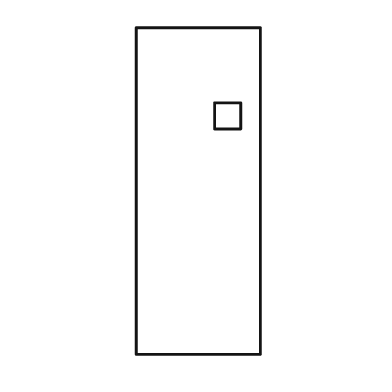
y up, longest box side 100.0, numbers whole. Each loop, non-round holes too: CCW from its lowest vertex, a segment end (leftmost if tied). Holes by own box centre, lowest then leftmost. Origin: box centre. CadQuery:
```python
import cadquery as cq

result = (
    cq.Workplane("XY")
    .moveTo(-19.0, -50.0)
    .lineTo(19.0, -50.0)
    .lineTo(19.0, 50.0)
    .lineTo(-19.0, 50.0)
    .close()
    .moveTo(5.0, 19.0)
    .lineTo(13.0, 19.0)
    .lineTo(13.0, 27.0)
    .lineTo(5.0, 27.0)
    .close()
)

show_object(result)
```